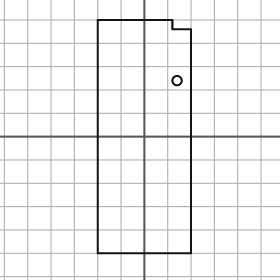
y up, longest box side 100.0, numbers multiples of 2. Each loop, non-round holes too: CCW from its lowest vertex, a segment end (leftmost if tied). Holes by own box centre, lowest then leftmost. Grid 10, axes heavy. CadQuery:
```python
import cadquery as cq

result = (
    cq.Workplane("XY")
    .moveTo(-20.0, -50.0)
    .lineTo(20.0, -50.0)
    .lineTo(20.0, 46.0)
    .lineTo(12.0, 46.0)
    .lineTo(12.0, 50.0)
    .lineTo(-20.0, 50.0)
    .close()
    .moveTo(14.0, 24.0)
    .circle(2.0)
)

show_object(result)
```